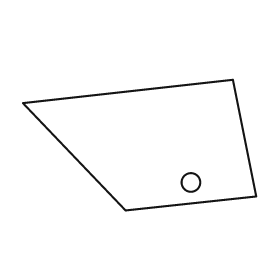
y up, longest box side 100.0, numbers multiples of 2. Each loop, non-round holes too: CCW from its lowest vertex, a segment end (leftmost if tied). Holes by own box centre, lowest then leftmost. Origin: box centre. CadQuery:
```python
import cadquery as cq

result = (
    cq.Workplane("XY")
    .moveTo(-6.0, -28.0)
    .lineTo(50.0, -22.0)
    .lineTo(40.0, 28.0)
    .lineTo(-50.0, 18.0)
    .close()
    .moveTo(22.0, -16.0)
    .circle(4.0)
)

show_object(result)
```